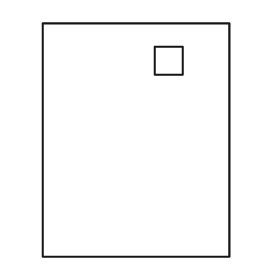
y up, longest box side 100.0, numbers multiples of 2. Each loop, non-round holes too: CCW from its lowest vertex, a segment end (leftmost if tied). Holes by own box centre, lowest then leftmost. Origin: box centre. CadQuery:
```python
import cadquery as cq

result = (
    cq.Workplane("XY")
    .moveTo(-40.0, -50.0)
    .lineTo(40.0, -50.0)
    .lineTo(40.0, 50.0)
    .lineTo(-40.0, 50.0)
    .close()
    .moveTo(8.0, 28.0)
    .lineTo(20.0, 28.0)
    .lineTo(20.0, 40.0)
    .lineTo(8.0, 40.0)
    .close()
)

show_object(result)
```